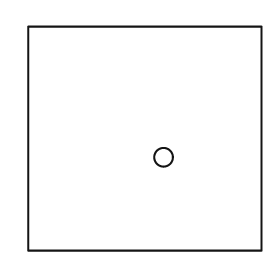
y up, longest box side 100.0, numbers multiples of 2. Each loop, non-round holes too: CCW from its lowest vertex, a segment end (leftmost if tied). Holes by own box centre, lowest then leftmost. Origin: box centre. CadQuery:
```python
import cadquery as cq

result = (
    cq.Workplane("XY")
    .moveTo(-50.0, -48.0)
    .lineTo(50.0, -48.0)
    .lineTo(50.0, 48.0)
    .lineTo(-50.0, 48.0)
    .close()
    .moveTo(8.0, -8.0)
    .circle(4.0)
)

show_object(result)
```